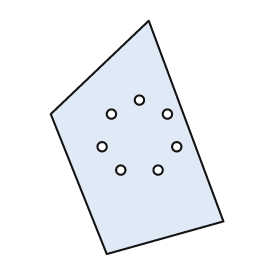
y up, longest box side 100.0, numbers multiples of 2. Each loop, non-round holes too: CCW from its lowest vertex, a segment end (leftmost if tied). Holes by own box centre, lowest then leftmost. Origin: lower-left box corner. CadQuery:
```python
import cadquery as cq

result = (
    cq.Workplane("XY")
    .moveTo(24.0, 0.0)
    .lineTo(74.0, 14.0)
    .lineTo(42.0, 100.0)
    .lineTo(0.0, 60.0)
    .close()
    .moveTo(30.0, 36.0)
    .circle(2.0)
    .moveTo(46.0, 36.0)
    .circle(2.0)
    .moveTo(22.0, 46.0)
    .circle(2.0)
    .moveTo(54.0, 46.0)
    .circle(2.0)
    .moveTo(26.0, 60.0)
    .circle(2.0)
    .moveTo(50.0, 60.0)
    .circle(2.0)
    .moveTo(38.0, 66.0)
    .circle(2.0)
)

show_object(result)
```